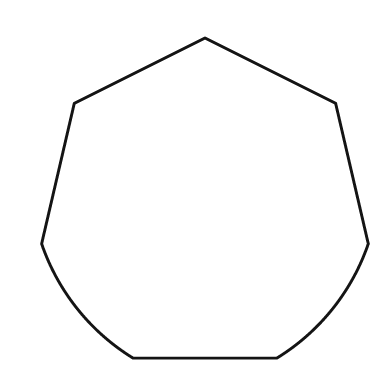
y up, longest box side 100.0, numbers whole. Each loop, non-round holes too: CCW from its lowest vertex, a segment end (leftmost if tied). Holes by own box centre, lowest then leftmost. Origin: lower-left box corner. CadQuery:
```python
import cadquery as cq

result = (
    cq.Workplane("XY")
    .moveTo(28.0, 0.0)
    .lineTo(72.0, 0.0)
    .threePointArc((89.0, 15.0), (100.0, 35.0))
    .lineTo(90.0, 78.0)
    .lineTo(50.0, 98.0)
    .lineTo(10.0, 78.0)
    .lineTo(0.0, 35.0)
    .threePointArc((11.0, 15.0), (28.0, 0.0))
    .close()
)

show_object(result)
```